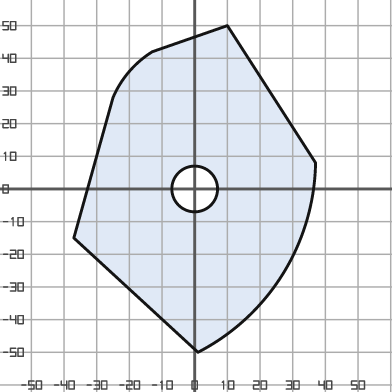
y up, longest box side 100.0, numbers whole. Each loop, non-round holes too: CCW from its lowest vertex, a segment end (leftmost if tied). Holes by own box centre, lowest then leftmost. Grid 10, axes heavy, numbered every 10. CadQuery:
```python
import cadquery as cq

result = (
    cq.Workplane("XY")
    .moveTo(1.0, -50.0)
    .threePointArc((27.0, -26.0), (37.0, 8.0))
    .lineTo(10.0, 50.0)
    .lineTo(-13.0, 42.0)
    .threePointArc((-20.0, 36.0), (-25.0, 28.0))
    .lineTo(-37.0, -15.0)
    .close()
    .moveTo(0.0, 0.0)
    .circle(7.0)
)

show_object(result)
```